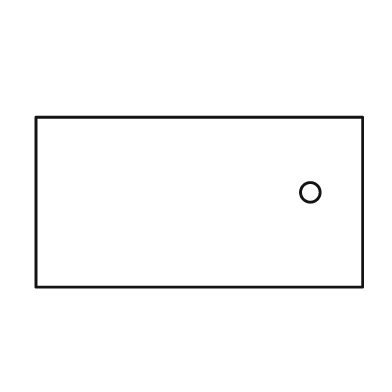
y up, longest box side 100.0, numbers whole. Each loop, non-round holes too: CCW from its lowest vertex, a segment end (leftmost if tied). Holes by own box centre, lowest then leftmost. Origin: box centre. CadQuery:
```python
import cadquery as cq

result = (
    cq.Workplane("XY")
    .moveTo(-50.0, -26.0)
    .lineTo(50.0, -26.0)
    .lineTo(50.0, 26.0)
    .lineTo(-50.0, 26.0)
    .close()
    .moveTo(34.0, 3.0)
    .circle(3.0)
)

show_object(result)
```